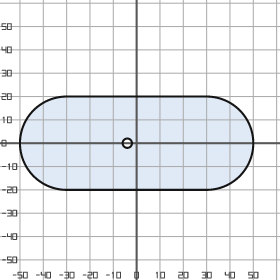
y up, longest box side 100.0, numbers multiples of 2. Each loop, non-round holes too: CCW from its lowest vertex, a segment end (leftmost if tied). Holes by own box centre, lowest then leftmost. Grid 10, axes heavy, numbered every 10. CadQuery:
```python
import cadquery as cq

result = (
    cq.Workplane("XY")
    .moveTo(-30.0, -20.0)
    .lineTo(30.0, -20.0)
    .threePointArc((50.0, 0.0), (30.0, 20.0))
    .lineTo(-30.0, 20.0)
    .threePointArc((-50.0, 0.0), (-30.0, -20.0))
    .close()
    .moveTo(-4.0, 0.0)
    .circle(2.0)
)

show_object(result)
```